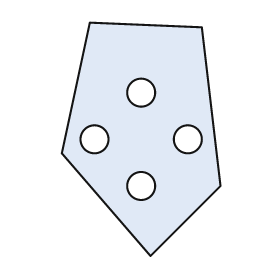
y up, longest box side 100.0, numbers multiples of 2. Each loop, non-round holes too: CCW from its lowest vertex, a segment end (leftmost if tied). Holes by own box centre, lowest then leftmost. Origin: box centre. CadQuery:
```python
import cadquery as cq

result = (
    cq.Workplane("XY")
    .moveTo(4.0, -50.0)
    .lineTo(34.0, -20.0)
    .lineTo(26.0, 48.0)
    .lineTo(-22.0, 50.0)
    .lineTo(-34.0, -6.0)
    .close()
    .moveTo(0.0, -20.0)
    .circle(6.0)
    .moveTo(-20.0, 0.0)
    .circle(6.0)
    .moveTo(20.0, 0.0)
    .circle(6.0)
    .moveTo(0.0, 20.0)
    .circle(6.0)
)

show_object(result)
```